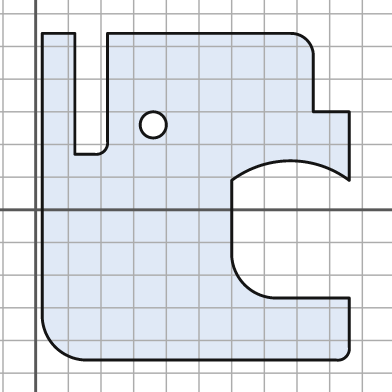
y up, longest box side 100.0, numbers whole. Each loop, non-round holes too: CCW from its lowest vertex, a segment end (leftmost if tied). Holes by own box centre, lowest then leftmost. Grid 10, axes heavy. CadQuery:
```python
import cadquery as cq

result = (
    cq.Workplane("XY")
    .moveTo(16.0, -46.0)
    .lineTo(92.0, -46.0)
    .threePointArc((95.0, -45.0), (96.0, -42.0))
    .lineTo(96.0, -27.0)
    .lineTo(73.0, -27.0)
    .threePointArc((64.0, -23.0), (60.0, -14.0))
    .lineTo(60.0, 9.0)
    .threePointArc((78.0, 15.0), (96.0, 9.0))
    .lineTo(96.0, 30.0)
    .lineTo(85.0, 30.0)
    .lineTo(85.0, 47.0)
    .threePointArc((83.0, 52.0), (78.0, 54.0))
    .lineTo(22.0, 54.0)
    .lineTo(22.0, 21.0)
    .threePointArc((21.0, 18.0), (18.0, 17.0))
    .lineTo(12.0, 17.0)
    .lineTo(12.0, 54.0)
    .lineTo(2.0, 54.0)
    .lineTo(2.0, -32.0)
    .threePointArc((6.0, -42.0), (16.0, -46.0))
    .close()
    .moveTo(36.0, 26.0)
    .circle(4.0)
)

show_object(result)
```